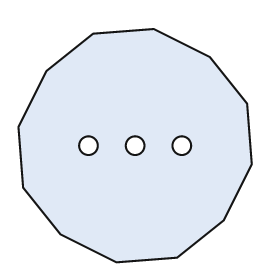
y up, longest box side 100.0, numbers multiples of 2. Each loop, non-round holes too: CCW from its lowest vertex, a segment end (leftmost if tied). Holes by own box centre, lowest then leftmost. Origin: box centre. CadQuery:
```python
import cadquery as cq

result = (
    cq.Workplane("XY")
    .moveTo(-8.0, -50.0)
    .lineTo(18.0, -48.0)
    .lineTo(38.0, -32.0)
    .lineTo(50.0, -8.0)
    .lineTo(48.0, 18.0)
    .lineTo(32.0, 38.0)
    .lineTo(8.0, 50.0)
    .lineTo(-18.0, 48.0)
    .lineTo(-38.0, 32.0)
    .lineTo(-50.0, 8.0)
    .lineTo(-48.0, -18.0)
    .lineTo(-32.0, -38.0)
    .close()
    .moveTo(-20.0, 0.0)
    .circle(4.0)
    .moveTo(0.0, 0.0)
    .circle(4.0)
    .moveTo(20.0, 0.0)
    .circle(4.0)
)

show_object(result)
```